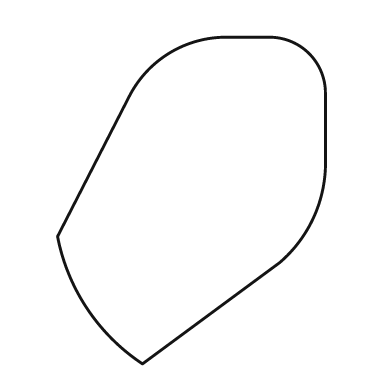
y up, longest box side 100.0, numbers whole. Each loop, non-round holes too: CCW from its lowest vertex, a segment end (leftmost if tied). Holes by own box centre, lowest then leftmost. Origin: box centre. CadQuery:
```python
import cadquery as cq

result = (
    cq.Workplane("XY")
    .moveTo(-15.0, -50.0)
    .lineTo(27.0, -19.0)
    .threePointArc((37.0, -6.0), (41.0, 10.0))
    .lineTo(41.0, 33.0)
    .threePointArc((36.0, 45.0), (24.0, 50.0))
    .lineTo(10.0, 50.0)
    .threePointArc((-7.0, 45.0), (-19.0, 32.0))
    .lineTo(-41.0, -11.0)
    .threePointArc((-32.0, -33.0), (-15.0, -50.0))
    .close()
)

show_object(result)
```